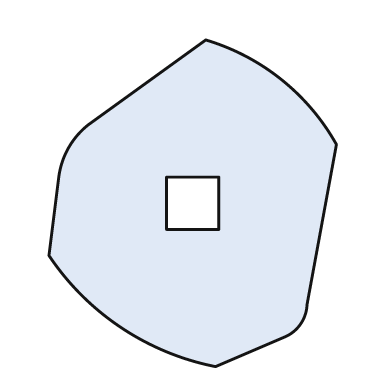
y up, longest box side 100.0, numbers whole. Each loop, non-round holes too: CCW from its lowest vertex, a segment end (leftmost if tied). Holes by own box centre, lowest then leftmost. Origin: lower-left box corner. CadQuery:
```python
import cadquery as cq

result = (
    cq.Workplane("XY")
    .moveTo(51.0, 0.0)
    .lineTo(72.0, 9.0)
    .threePointArc((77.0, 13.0), (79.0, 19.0))
    .lineTo(88.0, 68.0)
    .threePointArc((71.0, 88.0), (48.0, 100.0))
    .lineTo(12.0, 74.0)
    .threePointArc((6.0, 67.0), (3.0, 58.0))
    .lineTo(0.0, 34.0)
    .threePointArc((22.0, 12.0), (51.0, 0.0))
    .close()
    .moveTo(36.0, 42.0)
    .lineTo(52.0, 42.0)
    .lineTo(52.0, 58.0)
    .lineTo(36.0, 58.0)
    .close()
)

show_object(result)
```